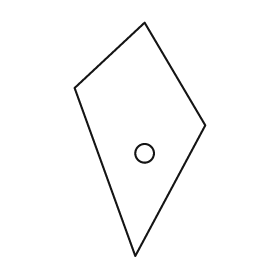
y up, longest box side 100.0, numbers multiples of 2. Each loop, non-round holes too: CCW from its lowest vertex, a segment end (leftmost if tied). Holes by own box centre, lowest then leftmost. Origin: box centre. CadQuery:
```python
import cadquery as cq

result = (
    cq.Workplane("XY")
    .moveTo(-2.0, -50.0)
    .lineTo(28.0, 6.0)
    .lineTo(2.0, 50.0)
    .lineTo(-28.0, 22.0)
    .close()
    .moveTo(2.0, -6.0)
    .circle(4.0)
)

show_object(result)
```